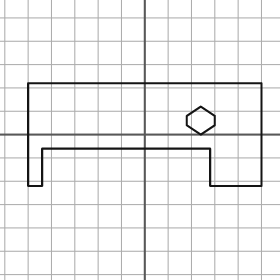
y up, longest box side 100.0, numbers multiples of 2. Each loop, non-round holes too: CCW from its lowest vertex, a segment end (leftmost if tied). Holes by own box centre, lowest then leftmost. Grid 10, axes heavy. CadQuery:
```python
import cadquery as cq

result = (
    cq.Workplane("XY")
    .moveTo(-50.0, -22.0)
    .lineTo(-44.0, -22.0)
    .lineTo(-44.0, -6.0)
    .lineTo(28.0, -6.0)
    .lineTo(28.0, -22.0)
    .lineTo(50.0, -22.0)
    .lineTo(50.0, 22.0)
    .lineTo(-50.0, 22.0)
    .close()
    .moveTo(24.0, 0.0)
    .lineTo(30.0, 4.0)
    .lineTo(30.0, 8.0)
    .lineTo(24.0, 12.0)
    .lineTo(18.0, 8.0)
    .lineTo(18.0, 4.0)
    .close()
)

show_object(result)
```